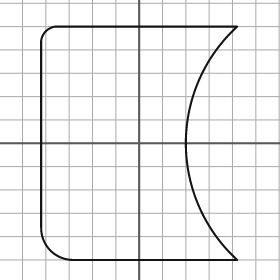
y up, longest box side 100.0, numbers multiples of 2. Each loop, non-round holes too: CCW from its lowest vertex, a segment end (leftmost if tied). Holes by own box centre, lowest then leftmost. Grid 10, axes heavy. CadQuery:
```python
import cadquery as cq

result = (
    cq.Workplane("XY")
    .moveTo(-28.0, -50.0)
    .lineTo(42.0, -50.0)
    .threePointArc((20.0, 0.0), (42.0, 50.0))
    .lineTo(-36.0, 50.0)
    .threePointArc((-40.0, 48.0), (-42.0, 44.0))
    .lineTo(-42.0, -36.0)
    .threePointArc((-38.0, -46.0), (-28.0, -50.0))
    .close()
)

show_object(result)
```